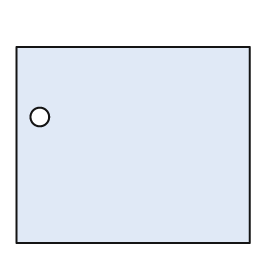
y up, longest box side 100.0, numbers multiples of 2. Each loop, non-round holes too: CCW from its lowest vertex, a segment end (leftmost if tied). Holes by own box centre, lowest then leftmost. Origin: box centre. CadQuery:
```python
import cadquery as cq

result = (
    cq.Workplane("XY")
    .moveTo(-50.0, -42.0)
    .lineTo(50.0, -42.0)
    .lineTo(50.0, 42.0)
    .lineTo(-50.0, 42.0)
    .close()
    .moveTo(-40.0, 12.0)
    .circle(4.0)
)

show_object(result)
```